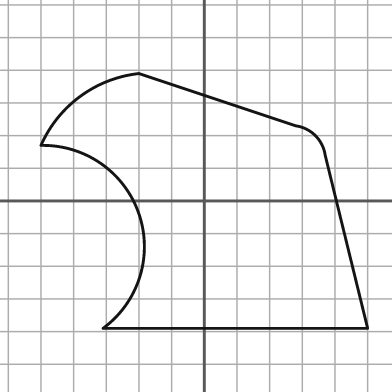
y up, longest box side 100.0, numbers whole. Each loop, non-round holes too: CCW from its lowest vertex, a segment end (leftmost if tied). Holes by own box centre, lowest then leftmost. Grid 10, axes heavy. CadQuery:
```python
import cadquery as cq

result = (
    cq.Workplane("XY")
    .moveTo(-31.0, -39.0)
    .lineTo(50.0, -39.0)
    .lineTo(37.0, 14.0)
    .threePointArc((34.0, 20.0), (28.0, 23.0))
    .lineTo(-20.0, 39.0)
    .threePointArc((-38.0, 32.0), (-50.0, 17.0))
    .threePointArc((-20.0, -4.0), (-31.0, -39.0))
    .close()
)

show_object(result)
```